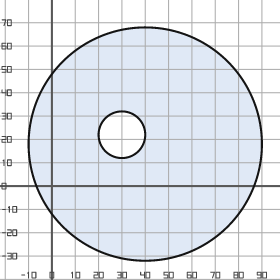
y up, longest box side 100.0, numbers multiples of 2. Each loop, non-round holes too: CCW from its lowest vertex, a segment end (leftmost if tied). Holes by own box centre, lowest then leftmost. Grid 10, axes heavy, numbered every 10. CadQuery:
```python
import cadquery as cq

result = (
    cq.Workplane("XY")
    .moveTo(40.0, 18.0)
    .circle(50.0)
    .moveTo(30.0, 22.0)
    .circle(10.0)
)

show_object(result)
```